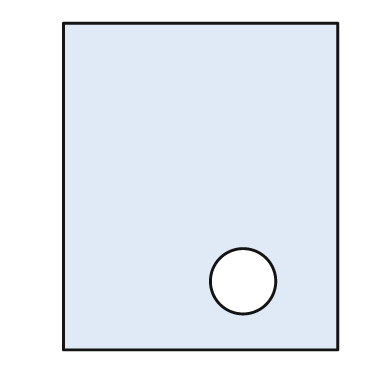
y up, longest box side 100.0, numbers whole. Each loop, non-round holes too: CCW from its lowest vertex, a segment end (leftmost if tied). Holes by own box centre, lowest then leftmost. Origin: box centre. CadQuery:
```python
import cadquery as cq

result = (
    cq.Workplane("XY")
    .moveTo(-42.0, -50.0)
    .lineTo(42.0, -50.0)
    .lineTo(42.0, 50.0)
    .lineTo(-42.0, 50.0)
    .close()
    .moveTo(13.0, -29.0)
    .circle(10.0)
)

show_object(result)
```